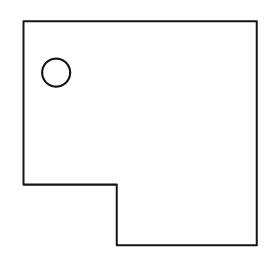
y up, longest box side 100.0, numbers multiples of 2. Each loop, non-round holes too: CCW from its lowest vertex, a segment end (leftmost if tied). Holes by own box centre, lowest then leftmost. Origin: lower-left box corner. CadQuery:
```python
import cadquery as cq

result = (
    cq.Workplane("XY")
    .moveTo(40.0, 0.0)
    .lineTo(100.0, 0.0)
    .lineTo(100.0, 96.0)
    .lineTo(0.0, 96.0)
    .lineTo(0.0, 26.0)
    .lineTo(40.0, 26.0)
    .close()
    .moveTo(14.0, 74.0)
    .circle(6.0)
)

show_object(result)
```